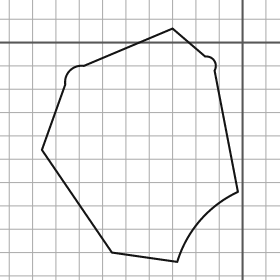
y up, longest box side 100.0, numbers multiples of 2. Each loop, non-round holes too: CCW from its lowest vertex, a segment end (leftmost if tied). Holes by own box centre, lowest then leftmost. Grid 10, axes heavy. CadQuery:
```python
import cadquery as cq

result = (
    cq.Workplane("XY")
    .moveTo(-28.0, -94.0)
    .threePointArc((-18.0, -76.0), (-2.0, -64.0))
    .lineTo(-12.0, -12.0)
    .threePointArc((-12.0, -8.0), (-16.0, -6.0))
    .lineTo(-30.0, 6.0)
    .lineTo(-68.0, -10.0)
    .threePointArc((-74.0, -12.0), (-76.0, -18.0))
    .lineTo(-86.0, -46.0)
    .lineTo(-56.0, -90.0)
    .close()
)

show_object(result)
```